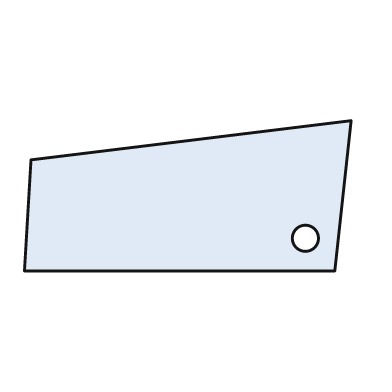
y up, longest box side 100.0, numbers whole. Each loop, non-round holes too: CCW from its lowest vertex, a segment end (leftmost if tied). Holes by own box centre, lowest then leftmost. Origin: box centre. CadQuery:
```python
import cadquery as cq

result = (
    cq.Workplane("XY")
    .moveTo(-50.0, -23.0)
    .lineTo(45.0, -23.0)
    .lineTo(50.0, 23.0)
    .lineTo(-48.0, 11.0)
    .close()
    .moveTo(36.0, -13.0)
    .circle(4.0)
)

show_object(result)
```